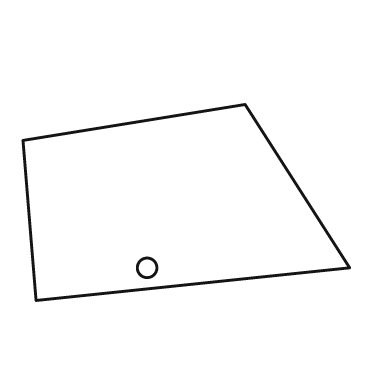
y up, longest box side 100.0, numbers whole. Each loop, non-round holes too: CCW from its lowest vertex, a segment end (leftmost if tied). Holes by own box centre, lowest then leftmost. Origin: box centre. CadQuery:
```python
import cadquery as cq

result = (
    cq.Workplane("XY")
    .moveTo(-46.0, -30.0)
    .lineTo(50.0, -20.0)
    .lineTo(18.0, 30.0)
    .lineTo(-50.0, 19.0)
    .close()
    .moveTo(-12.0, -20.0)
    .circle(3.0)
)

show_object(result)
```